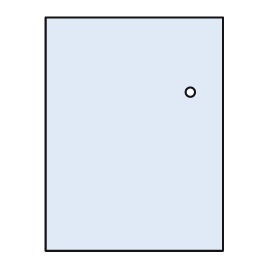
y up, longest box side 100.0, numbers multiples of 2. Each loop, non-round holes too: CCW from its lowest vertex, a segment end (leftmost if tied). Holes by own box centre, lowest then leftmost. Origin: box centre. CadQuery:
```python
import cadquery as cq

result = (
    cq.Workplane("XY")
    .moveTo(-38.0, -50.0)
    .lineTo(38.0, -50.0)
    .lineTo(38.0, 50.0)
    .lineTo(-38.0, 50.0)
    .close()
    .moveTo(24.0, 18.0)
    .circle(2.0)
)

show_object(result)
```